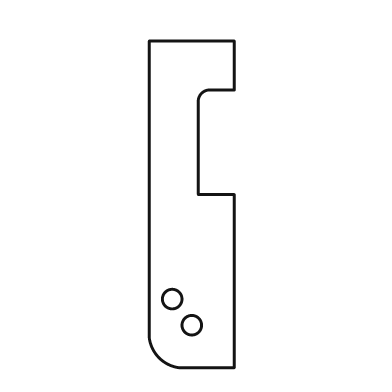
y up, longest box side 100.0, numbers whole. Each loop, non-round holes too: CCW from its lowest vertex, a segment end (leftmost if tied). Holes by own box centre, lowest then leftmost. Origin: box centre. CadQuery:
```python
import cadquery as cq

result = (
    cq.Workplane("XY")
    .moveTo(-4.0, -50.0)
    .lineTo(13.0, -50.0)
    .lineTo(13.0, 3.0)
    .lineTo(2.0, 3.0)
    .lineTo(2.0, 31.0)
    .threePointArc((3.0, 34.0), (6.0, 35.0))
    .lineTo(13.0, 35.0)
    .lineTo(13.0, 50.0)
    .lineTo(-13.0, 50.0)
    .lineTo(-13.0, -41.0)
    .threePointArc((-10.0, -47.0), (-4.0, -50.0))
    .close()
    .moveTo(0.0, -37.0)
    .circle(3.0)
    .moveTo(-6.0, -29.0)
    .circle(3.0)
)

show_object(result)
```